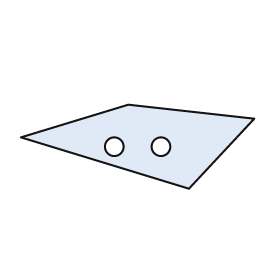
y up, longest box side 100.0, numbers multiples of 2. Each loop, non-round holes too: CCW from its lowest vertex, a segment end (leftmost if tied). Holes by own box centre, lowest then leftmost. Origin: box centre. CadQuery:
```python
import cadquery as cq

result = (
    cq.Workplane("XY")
    .moveTo(22.0, -18.0)
    .lineTo(50.0, 12.0)
    .lineTo(-4.0, 18.0)
    .lineTo(-50.0, 4.0)
    .close()
    .moveTo(-10.0, 0.0)
    .circle(4.0)
    .moveTo(10.0, 0.0)
    .circle(4.0)
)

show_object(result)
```